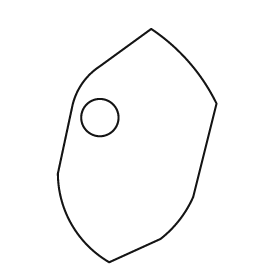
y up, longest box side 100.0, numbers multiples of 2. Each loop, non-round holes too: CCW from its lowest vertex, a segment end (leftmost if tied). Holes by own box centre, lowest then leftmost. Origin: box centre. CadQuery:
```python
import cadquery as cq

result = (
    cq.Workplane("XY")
    .moveTo(-12.0, -50.0)
    .lineTo(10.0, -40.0)
    .threePointArc((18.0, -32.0), (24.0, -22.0))
    .lineTo(34.0, 18.0)
    .threePointArc((22.0, 36.0), (6.0, 50.0))
    .lineTo(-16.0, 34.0)
    .threePointArc((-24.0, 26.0), (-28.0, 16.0))
    .lineTo(-34.0, -12.0)
    .threePointArc((-28.0, -34.0), (-12.0, -50.0))
    .close()
    .moveTo(-16.0, 12.0)
    .circle(8.0)
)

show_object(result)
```